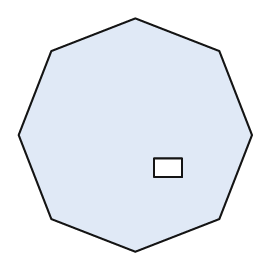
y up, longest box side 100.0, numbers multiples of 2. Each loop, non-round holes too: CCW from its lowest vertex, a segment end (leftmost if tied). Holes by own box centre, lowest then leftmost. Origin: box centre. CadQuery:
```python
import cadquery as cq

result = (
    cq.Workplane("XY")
    .moveTo(0.0, -50.0)
    .lineTo(36.0, -36.0)
    .lineTo(50.0, 0.0)
    .lineTo(36.0, 36.0)
    .lineTo(0.0, 50.0)
    .lineTo(-36.0, 36.0)
    .lineTo(-50.0, 0.0)
    .lineTo(-36.0, -36.0)
    .close()
    .moveTo(8.0, -18.0)
    .lineTo(20.0, -18.0)
    .lineTo(20.0, -10.0)
    .lineTo(8.0, -10.0)
    .close()
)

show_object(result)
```